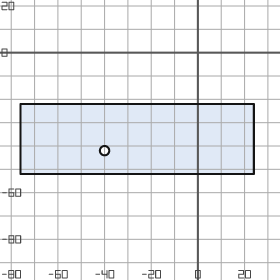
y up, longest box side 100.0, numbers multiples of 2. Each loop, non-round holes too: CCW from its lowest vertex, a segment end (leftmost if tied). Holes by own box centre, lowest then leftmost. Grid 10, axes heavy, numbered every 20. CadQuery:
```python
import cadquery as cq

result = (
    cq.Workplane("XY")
    .moveTo(-76.0, -52.0)
    .lineTo(24.0, -52.0)
    .lineTo(24.0, -22.0)
    .lineTo(-76.0, -22.0)
    .close()
    .moveTo(-40.0, -42.0)
    .circle(2.0)
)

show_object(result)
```